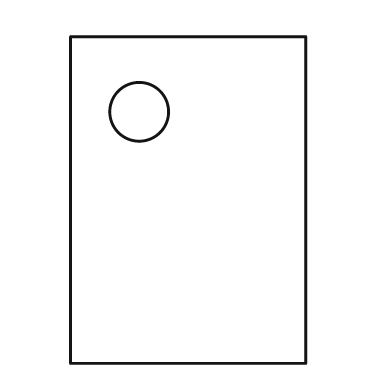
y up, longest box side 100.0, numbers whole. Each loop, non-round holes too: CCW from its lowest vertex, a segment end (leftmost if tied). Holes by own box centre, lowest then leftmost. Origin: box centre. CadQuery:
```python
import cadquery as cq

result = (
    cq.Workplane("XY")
    .moveTo(-36.0, -50.0)
    .lineTo(36.0, -50.0)
    .lineTo(36.0, 50.0)
    .lineTo(-36.0, 50.0)
    .close()
    .moveTo(-15.0, 27.0)
    .circle(9.0)
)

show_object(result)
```